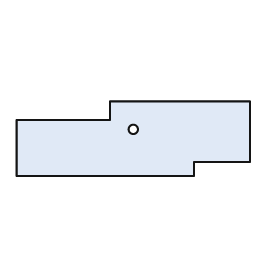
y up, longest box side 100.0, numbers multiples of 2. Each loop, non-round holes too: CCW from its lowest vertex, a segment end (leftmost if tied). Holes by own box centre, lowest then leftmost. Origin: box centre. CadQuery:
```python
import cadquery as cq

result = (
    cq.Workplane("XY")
    .moveTo(-50.0, -16.0)
    .lineTo(26.0, -16.0)
    .lineTo(26.0, -10.0)
    .lineTo(50.0, -10.0)
    .lineTo(50.0, 16.0)
    .lineTo(-10.0, 16.0)
    .lineTo(-10.0, 8.0)
    .lineTo(-50.0, 8.0)
    .close()
    .moveTo(0.0, 4.0)
    .circle(2.0)
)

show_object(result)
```